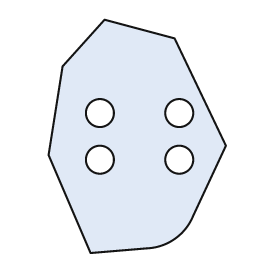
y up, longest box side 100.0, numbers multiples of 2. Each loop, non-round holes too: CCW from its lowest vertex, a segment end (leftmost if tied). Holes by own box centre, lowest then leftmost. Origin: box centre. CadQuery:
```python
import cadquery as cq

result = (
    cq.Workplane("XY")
    .moveTo(-20.0, -50.0)
    .lineTo(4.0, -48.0)
    .threePointArc((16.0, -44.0), (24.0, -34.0))
    .lineTo(38.0, -4.0)
    .lineTo(16.0, 42.0)
    .lineTo(-14.0, 50.0)
    .lineTo(-32.0, 30.0)
    .lineTo(-38.0, -8.0)
    .close()
    .moveTo(-16.0, -10.0)
    .circle(6.0)
    .moveTo(18.0, -10.0)
    .circle(6.0)
    .moveTo(-16.0, 10.0)
    .circle(6.0)
    .moveTo(18.0, 10.0)
    .circle(6.0)
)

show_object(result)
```